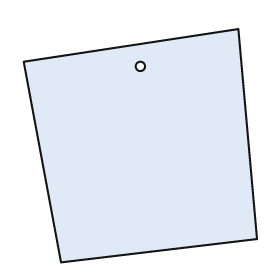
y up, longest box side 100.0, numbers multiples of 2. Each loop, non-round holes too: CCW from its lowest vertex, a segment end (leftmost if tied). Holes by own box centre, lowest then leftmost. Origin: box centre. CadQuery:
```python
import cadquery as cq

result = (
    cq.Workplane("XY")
    .moveTo(-34.0, -50.0)
    .lineTo(50.0, -40.0)
    .lineTo(42.0, 50.0)
    .lineTo(-50.0, 36.0)
    .close()
    .moveTo(0.0, 34.0)
    .circle(2.0)
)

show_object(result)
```